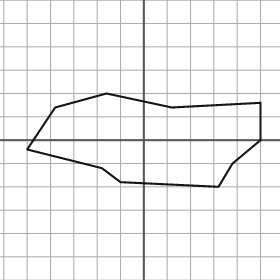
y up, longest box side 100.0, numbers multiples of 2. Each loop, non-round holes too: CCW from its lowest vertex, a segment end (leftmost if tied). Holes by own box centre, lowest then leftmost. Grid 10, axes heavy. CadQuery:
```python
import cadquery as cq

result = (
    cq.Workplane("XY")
    .moveTo(32.0, -20.0)
    .lineTo(38.0, -10.0)
    .lineTo(50.0, 0.0)
    .lineTo(50.0, 16.0)
    .lineTo(12.0, 14.0)
    .lineTo(-16.0, 20.0)
    .lineTo(-38.0, 14.0)
    .lineTo(-50.0, -4.0)
    .lineTo(-18.0, -12.0)
    .lineTo(-10.0, -18.0)
    .close()
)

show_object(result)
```